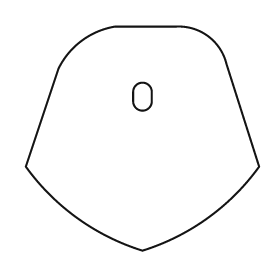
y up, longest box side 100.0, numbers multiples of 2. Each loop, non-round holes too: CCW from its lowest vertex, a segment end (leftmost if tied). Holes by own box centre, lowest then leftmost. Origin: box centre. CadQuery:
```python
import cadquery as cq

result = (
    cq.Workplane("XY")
    .moveTo(0.0, -48.0)
    .threePointArc((28.0, -34.0), (50.0, -12.0))
    .lineTo(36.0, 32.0)
    .threePointArc((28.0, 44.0), (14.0, 48.0))
    .lineTo(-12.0, 48.0)
    .threePointArc((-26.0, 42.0), (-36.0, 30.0))
    .lineTo(-50.0, -12.0)
    .threePointArc((-28.0, -34.0), (0.0, -48.0))
    .close()
    .moveTo(-4.0, 16.0)
    .threePointArc((0.0, 12.0), (4.0, 16.0))
    .lineTo(4.0, 20.0)
    .threePointArc((0.0, 24.0), (-4.0, 20.0))
    .close()
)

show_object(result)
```